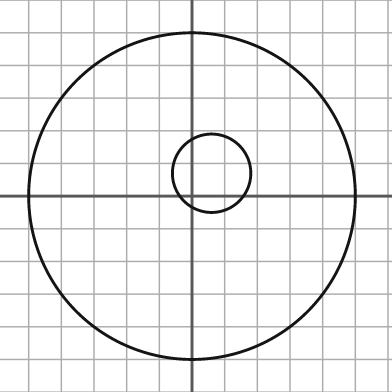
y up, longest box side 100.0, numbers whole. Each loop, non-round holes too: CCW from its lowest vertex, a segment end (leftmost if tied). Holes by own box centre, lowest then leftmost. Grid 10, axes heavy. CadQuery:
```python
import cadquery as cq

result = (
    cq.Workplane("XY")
    .moveTo(0.0, 0.0)
    .circle(50.0)
    .moveTo(6.0, 7.0)
    .circle(12.0)
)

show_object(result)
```